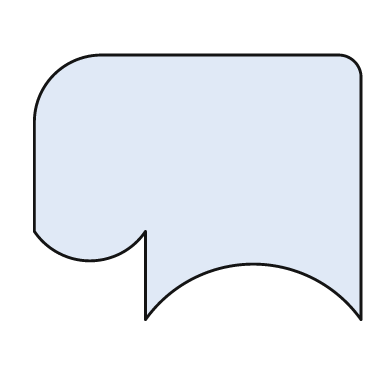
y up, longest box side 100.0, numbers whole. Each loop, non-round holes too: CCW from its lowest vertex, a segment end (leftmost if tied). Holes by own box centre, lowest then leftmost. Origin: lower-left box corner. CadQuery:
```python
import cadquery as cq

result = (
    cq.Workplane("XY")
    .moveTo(34.0, 0.0)
    .threePointArc((67.0, 17.0), (100.0, 0.0))
    .lineTo(100.0, 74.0)
    .threePointArc((98.0, 79.0), (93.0, 81.0))
    .lineTo(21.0, 81.0)
    .threePointArc((6.0, 75.0), (0.0, 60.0))
    .lineTo(0.0, 27.0)
    .threePointArc((17.0, 18.0), (34.0, 27.0))
    .close()
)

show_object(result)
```